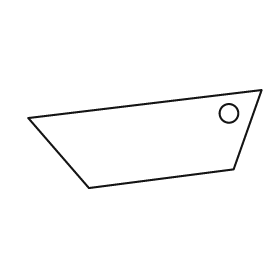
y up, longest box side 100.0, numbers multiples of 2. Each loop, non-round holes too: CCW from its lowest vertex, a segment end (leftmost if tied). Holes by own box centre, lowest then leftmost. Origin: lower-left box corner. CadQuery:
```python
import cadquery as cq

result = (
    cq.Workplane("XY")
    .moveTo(26.0, 0.0)
    .lineTo(88.0, 8.0)
    .lineTo(100.0, 42.0)
    .lineTo(0.0, 30.0)
    .close()
    .moveTo(86.0, 32.0)
    .circle(4.0)
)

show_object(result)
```